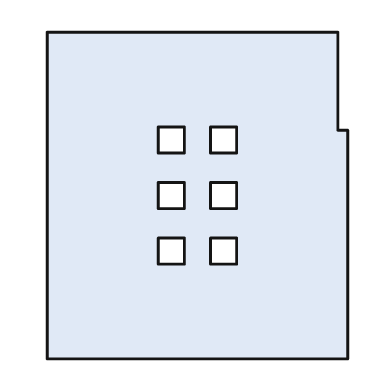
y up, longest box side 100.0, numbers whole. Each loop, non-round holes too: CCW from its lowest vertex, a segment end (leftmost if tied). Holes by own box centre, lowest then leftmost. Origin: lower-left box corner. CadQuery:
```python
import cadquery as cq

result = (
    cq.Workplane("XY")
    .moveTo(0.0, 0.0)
    .lineTo(92.0, 0.0)
    .lineTo(92.0, 70.0)
    .lineTo(89.0, 70.0)
    .lineTo(89.0, 100.0)
    .lineTo(0.0, 100.0)
    .close()
    .moveTo(34.0, 29.0)
    .lineTo(42.0, 29.0)
    .lineTo(42.0, 37.0)
    .lineTo(34.0, 37.0)
    .close()
    .moveTo(50.0, 29.0)
    .lineTo(58.0, 29.0)
    .lineTo(58.0, 37.0)
    .lineTo(50.0, 37.0)
    .close()
    .moveTo(34.0, 46.0)
    .lineTo(42.0, 46.0)
    .lineTo(42.0, 54.0)
    .lineTo(34.0, 54.0)
    .close()
    .moveTo(50.0, 46.0)
    .lineTo(58.0, 46.0)
    .lineTo(58.0, 54.0)
    .lineTo(50.0, 54.0)
    .close()
    .moveTo(34.0, 63.0)
    .lineTo(42.0, 63.0)
    .lineTo(42.0, 71.0)
    .lineTo(34.0, 71.0)
    .close()
    .moveTo(50.0, 63.0)
    .lineTo(58.0, 63.0)
    .lineTo(58.0, 71.0)
    .lineTo(50.0, 71.0)
    .close()
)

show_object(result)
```